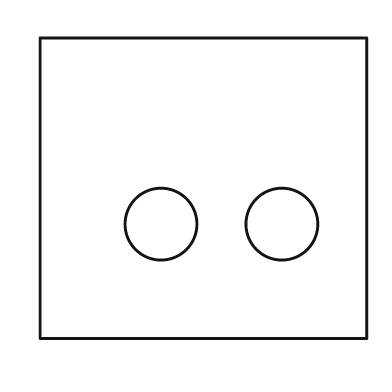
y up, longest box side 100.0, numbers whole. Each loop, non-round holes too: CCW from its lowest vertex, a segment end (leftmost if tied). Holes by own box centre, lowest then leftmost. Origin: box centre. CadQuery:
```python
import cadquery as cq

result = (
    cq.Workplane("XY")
    .moveTo(-50.0, -46.0)
    .lineTo(50.0, -46.0)
    .lineTo(50.0, 46.0)
    .lineTo(-50.0, 46.0)
    .close()
    .moveTo(-13.0, -11.0)
    .circle(11.0)
    .moveTo(24.0, -11.0)
    .circle(11.0)
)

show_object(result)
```